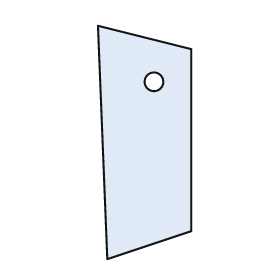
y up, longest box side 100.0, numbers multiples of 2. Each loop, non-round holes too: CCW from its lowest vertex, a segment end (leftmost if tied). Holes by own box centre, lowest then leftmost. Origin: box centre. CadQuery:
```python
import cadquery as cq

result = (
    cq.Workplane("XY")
    .moveTo(-16.0, -50.0)
    .lineTo(20.0, -38.0)
    .lineTo(20.0, 40.0)
    .lineTo(-20.0, 50.0)
    .close()
    .moveTo(4.0, 26.0)
    .circle(4.0)
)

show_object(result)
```